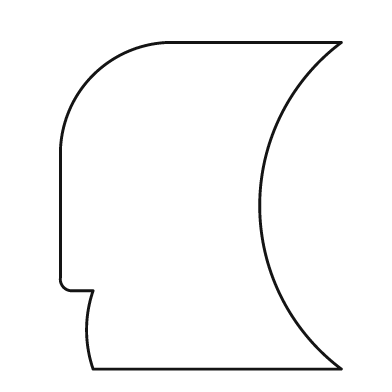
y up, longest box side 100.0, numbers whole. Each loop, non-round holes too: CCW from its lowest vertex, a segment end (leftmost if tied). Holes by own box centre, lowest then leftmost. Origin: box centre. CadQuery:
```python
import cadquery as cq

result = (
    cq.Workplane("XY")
    .moveTo(-33.0, -50.0)
    .lineTo(43.0, -50.0)
    .threePointArc((18.0, 0.0), (43.0, 50.0))
    .lineTo(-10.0, 50.0)
    .threePointArc((-33.0, 40.0), (-43.0, 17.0))
    .lineTo(-43.0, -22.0)
    .threePointArc((-42.0, -25.0), (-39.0, -26.0))
    .lineTo(-33.0, -26.0)
    .threePointArc((-35.0, -38.0), (-33.0, -50.0))
    .close()
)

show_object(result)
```